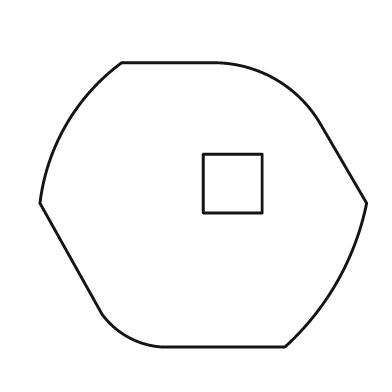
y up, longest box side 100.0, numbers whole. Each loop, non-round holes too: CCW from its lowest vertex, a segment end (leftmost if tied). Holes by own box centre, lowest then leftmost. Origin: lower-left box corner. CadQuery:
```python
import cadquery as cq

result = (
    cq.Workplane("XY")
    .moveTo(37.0, 0.0)
    .lineTo(75.0, 0.0)
    .threePointArc((91.0, 20.0), (100.0, 44.0))
    .lineTo(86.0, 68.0)
    .threePointArc((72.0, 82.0), (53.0, 87.0))
    .lineTo(25.0, 87.0)
    .threePointArc((8.0, 68.0), (0.0, 44.0))
    .lineTo(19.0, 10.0)
    .threePointArc((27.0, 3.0), (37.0, 0.0))
    .close()
    .moveTo(50.0, 41.0)
    .lineTo(68.0, 41.0)
    .lineTo(68.0, 59.0)
    .lineTo(50.0, 59.0)
    .close()
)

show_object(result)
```